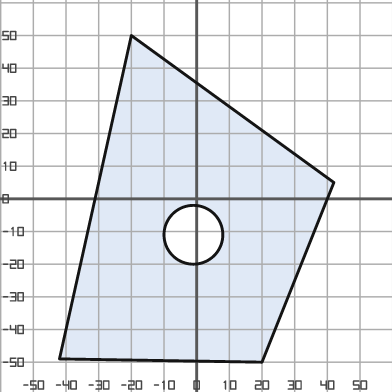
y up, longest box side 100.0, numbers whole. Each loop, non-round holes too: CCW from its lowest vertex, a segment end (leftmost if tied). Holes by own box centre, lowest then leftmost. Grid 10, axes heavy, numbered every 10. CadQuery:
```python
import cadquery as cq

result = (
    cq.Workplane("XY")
    .moveTo(20.0, -50.0)
    .lineTo(42.0, 5.0)
    .lineTo(-20.0, 50.0)
    .lineTo(-42.0, -49.0)
    .close()
    .moveTo(-1.0, -11.0)
    .circle(9.0)
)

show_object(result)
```